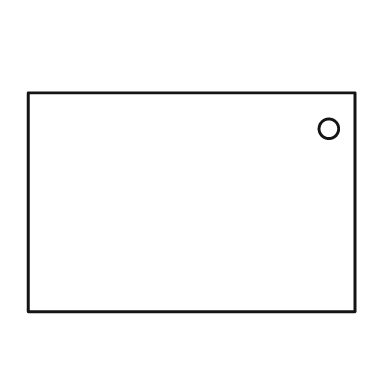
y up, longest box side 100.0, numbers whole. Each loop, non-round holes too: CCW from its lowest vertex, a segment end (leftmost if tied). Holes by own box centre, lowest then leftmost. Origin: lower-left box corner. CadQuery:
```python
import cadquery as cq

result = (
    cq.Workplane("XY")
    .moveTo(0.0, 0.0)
    .lineTo(100.0, 0.0)
    .lineTo(100.0, 67.0)
    .lineTo(0.0, 67.0)
    .close()
    .moveTo(92.0, 56.0)
    .circle(3.0)
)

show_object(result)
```